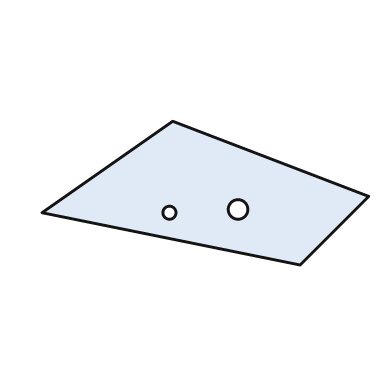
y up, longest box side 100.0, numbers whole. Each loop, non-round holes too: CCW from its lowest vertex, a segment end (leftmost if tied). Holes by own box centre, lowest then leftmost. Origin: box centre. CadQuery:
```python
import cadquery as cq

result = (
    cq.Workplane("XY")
    .moveTo(29.0, -22.0)
    .lineTo(50.0, -1.0)
    .lineTo(-10.0, 22.0)
    .lineTo(-50.0, -6.0)
    .close()
    .moveTo(-11.0, -6.0)
    .circle(2.0)
    .moveTo(10.0, -5.0)
    .circle(3.0)
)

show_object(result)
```